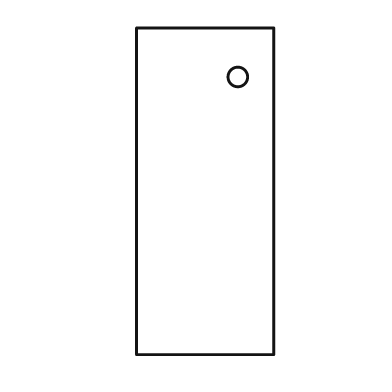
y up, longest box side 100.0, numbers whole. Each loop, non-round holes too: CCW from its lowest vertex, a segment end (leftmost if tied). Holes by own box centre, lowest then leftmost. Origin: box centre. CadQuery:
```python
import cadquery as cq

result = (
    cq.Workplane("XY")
    .moveTo(-21.0, -50.0)
    .lineTo(21.0, -50.0)
    .lineTo(21.0, 50.0)
    .lineTo(-21.0, 50.0)
    .close()
    .moveTo(10.0, 35.0)
    .circle(3.0)
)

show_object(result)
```